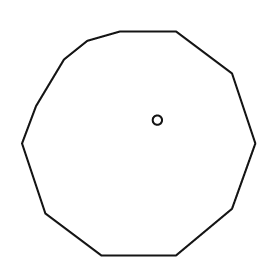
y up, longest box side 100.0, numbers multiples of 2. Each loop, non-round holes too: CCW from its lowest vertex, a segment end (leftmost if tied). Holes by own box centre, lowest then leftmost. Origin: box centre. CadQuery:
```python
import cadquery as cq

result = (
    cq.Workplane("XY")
    .moveTo(-16.0, -48.0)
    .lineTo(16.0, -48.0)
    .lineTo(40.0, -28.0)
    .lineTo(50.0, 0.0)
    .lineTo(40.0, 30.0)
    .lineTo(16.0, 48.0)
    .lineTo(-8.0, 48.0)
    .lineTo(-22.0, 44.0)
    .lineTo(-32.0, 36.0)
    .lineTo(-44.0, 16.0)
    .lineTo(-50.0, 0.0)
    .lineTo(-40.0, -30.0)
    .close()
    .moveTo(8.0, 10.0)
    .circle(2.0)
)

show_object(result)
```